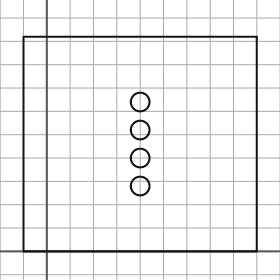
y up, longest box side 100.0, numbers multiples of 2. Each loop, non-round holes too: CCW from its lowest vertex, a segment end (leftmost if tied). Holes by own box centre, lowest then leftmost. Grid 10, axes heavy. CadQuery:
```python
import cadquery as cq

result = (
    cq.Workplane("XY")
    .moveTo(-10.0, 0.0)
    .lineTo(90.0, 0.0)
    .lineTo(90.0, 92.0)
    .lineTo(-10.0, 92.0)
    .close()
    .moveTo(40.0, 28.0)
    .circle(4.0)
    .moveTo(40.0, 40.0)
    .circle(4.0)
    .moveTo(40.0, 52.0)
    .circle(4.0)
    .moveTo(40.0, 64.0)
    .circle(4.0)
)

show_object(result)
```